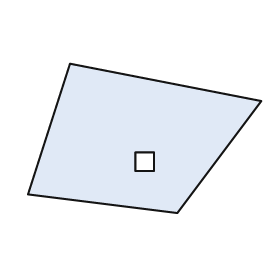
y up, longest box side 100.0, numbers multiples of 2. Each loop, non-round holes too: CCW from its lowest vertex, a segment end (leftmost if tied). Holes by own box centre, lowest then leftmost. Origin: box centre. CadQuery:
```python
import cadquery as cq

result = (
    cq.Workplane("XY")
    .moveTo(14.0, -32.0)
    .lineTo(50.0, 16.0)
    .lineTo(-32.0, 32.0)
    .lineTo(-50.0, -24.0)
    .close()
    .moveTo(-4.0, -14.0)
    .lineTo(4.0, -14.0)
    .lineTo(4.0, -6.0)
    .lineTo(-4.0, -6.0)
    .close()
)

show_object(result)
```